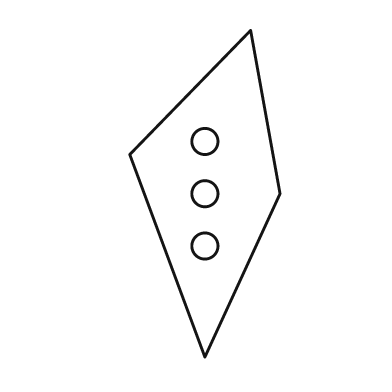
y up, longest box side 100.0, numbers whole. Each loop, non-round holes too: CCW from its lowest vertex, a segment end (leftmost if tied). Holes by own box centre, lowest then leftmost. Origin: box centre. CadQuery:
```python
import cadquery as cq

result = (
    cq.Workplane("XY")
    .moveTo(0.0, -50.0)
    .lineTo(23.0, 0.0)
    .lineTo(14.0, 50.0)
    .lineTo(-23.0, 12.0)
    .close()
    .moveTo(0.0, -16.0)
    .circle(4.0)
    .moveTo(0.0, 0.0)
    .circle(4.0)
    .moveTo(0.0, 16.0)
    .circle(4.0)
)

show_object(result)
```